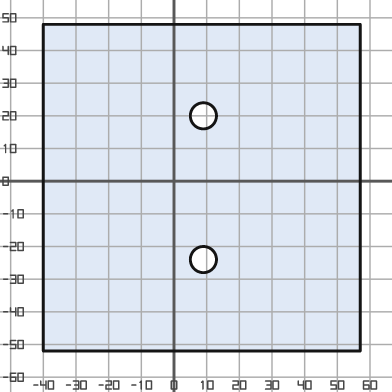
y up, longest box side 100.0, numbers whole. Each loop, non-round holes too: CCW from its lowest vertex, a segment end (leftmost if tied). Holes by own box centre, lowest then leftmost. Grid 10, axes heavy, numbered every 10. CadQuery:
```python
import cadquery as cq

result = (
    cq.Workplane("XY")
    .moveTo(-40.0, -52.0)
    .lineTo(57.0, -52.0)
    .lineTo(57.0, 48.0)
    .lineTo(-40.0, 48.0)
    .close()
    .moveTo(9.0, -24.0)
    .circle(4.0)
    .moveTo(9.0, 20.0)
    .circle(4.0)
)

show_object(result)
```